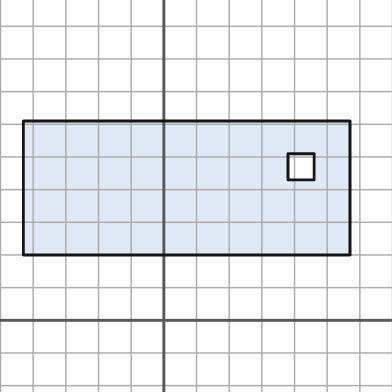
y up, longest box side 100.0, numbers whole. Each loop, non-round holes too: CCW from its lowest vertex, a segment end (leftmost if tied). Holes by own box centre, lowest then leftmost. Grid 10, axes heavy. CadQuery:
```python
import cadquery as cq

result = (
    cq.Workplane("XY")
    .moveTo(-43.0, 20.0)
    .lineTo(57.0, 20.0)
    .lineTo(57.0, 61.0)
    .lineTo(-43.0, 61.0)
    .close()
    .moveTo(38.0, 43.0)
    .lineTo(46.0, 43.0)
    .lineTo(46.0, 51.0)
    .lineTo(38.0, 51.0)
    .close()
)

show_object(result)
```